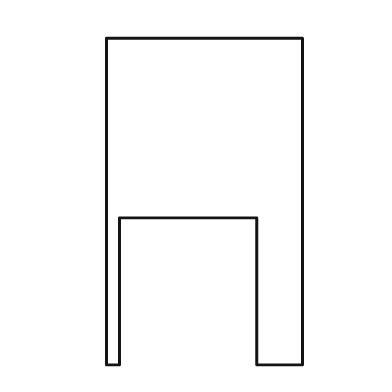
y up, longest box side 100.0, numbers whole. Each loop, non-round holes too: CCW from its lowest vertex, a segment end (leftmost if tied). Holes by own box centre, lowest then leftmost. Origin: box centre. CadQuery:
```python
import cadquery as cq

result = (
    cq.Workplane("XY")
    .moveTo(-30.0, -50.0)
    .lineTo(-26.0, -50.0)
    .lineTo(-26.0, -5.0)
    .lineTo(16.0, -5.0)
    .lineTo(16.0, -50.0)
    .lineTo(30.0, -50.0)
    .lineTo(30.0, 50.0)
    .lineTo(-30.0, 50.0)
    .close()
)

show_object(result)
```